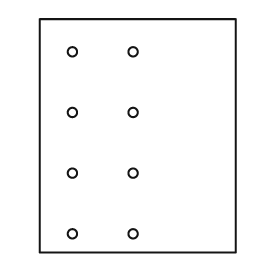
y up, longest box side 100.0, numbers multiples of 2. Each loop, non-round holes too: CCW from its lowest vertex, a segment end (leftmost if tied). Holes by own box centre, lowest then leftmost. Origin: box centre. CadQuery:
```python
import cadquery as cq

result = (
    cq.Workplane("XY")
    .moveTo(-42.0, -50.0)
    .lineTo(42.0, -50.0)
    .lineTo(42.0, 50.0)
    .lineTo(-42.0, 50.0)
    .close()
    .moveTo(-28.0, -42.0)
    .circle(2.0)
    .moveTo(-2.0, -42.0)
    .circle(2.0)
    .moveTo(-28.0, -16.0)
    .circle(2.0)
    .moveTo(-2.0, -16.0)
    .circle(2.0)
    .moveTo(-28.0, 10.0)
    .circle(2.0)
    .moveTo(-2.0, 10.0)
    .circle(2.0)
    .moveTo(-28.0, 36.0)
    .circle(2.0)
    .moveTo(-2.0, 36.0)
    .circle(2.0)
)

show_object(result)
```